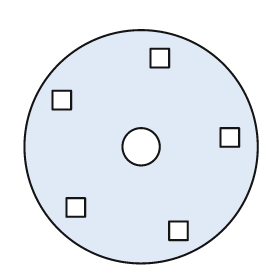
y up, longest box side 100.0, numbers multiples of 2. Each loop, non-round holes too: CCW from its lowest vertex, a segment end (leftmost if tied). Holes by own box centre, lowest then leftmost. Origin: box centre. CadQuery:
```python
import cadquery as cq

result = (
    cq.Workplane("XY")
    .moveTo(0.0, 0.0)
    .circle(50.0)
    .moveTo(12.0, -40.0)
    .lineTo(20.0, -40.0)
    .lineTo(20.0, -32.0)
    .lineTo(12.0, -32.0)
    .close()
    .moveTo(-32.0, -30.0)
    .lineTo(-24.0, -30.0)
    .lineTo(-24.0, -22.0)
    .lineTo(-32.0, -22.0)
    .close()
    .moveTo(0.0, 0.0)
    .circle(8.0)
    .moveTo(34.0, 0.0)
    .lineTo(42.0, 0.0)
    .lineTo(42.0, 8.0)
    .lineTo(34.0, 8.0)
    .close()
    .moveTo(-38.0, 16.0)
    .lineTo(-30.0, 16.0)
    .lineTo(-30.0, 24.0)
    .lineTo(-38.0, 24.0)
    .close()
    .moveTo(4.0, 34.0)
    .lineTo(12.0, 34.0)
    .lineTo(12.0, 42.0)
    .lineTo(4.0, 42.0)
    .close()
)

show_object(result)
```